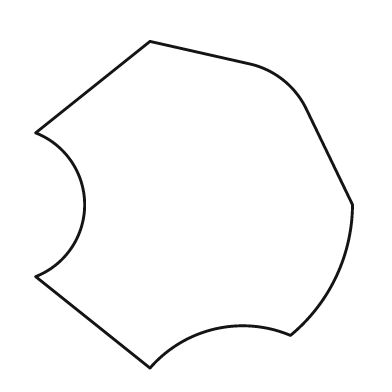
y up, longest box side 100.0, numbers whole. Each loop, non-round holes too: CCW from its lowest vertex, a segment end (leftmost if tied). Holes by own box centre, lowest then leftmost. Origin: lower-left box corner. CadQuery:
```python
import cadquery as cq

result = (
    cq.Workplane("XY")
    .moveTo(35.0, 0.0)
    .threePointArc((55.0, 12.0), (78.0, 10.0))
    .threePointArc((92.0, 28.0), (97.0, 50.0))
    .lineTo(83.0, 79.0)
    .threePointArc((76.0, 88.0), (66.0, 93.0))
    .lineTo(35.0, 100.0)
    .lineTo(0.0, 72.0)
    .threePointArc((15.0, 50.0), (0.0, 28.0))
    .close()
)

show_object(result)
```